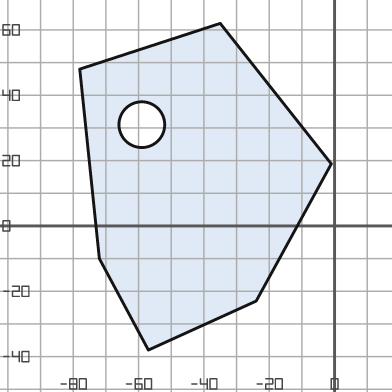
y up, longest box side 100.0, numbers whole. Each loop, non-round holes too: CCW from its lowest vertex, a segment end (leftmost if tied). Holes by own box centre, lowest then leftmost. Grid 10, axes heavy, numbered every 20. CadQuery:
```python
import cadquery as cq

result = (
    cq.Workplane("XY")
    .moveTo(-57.0, -38.0)
    .lineTo(-24.0, -23.0)
    .lineTo(-1.0, 19.0)
    .lineTo(-35.0, 62.0)
    .lineTo(-78.0, 48.0)
    .lineTo(-72.0, -10.0)
    .close()
    .moveTo(-59.0, 31.0)
    .circle(7.0)
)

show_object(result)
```